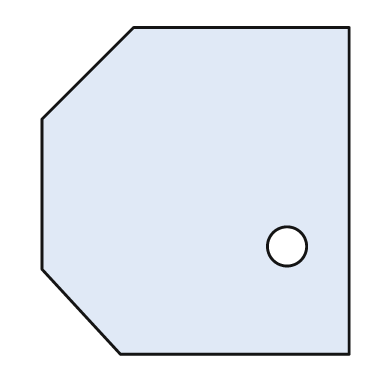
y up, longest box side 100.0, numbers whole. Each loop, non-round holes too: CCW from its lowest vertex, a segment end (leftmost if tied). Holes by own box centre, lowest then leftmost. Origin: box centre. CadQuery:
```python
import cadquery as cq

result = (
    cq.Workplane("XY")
    .moveTo(-23.0, -50.0)
    .lineTo(47.0, -50.0)
    .lineTo(47.0, 50.0)
    .lineTo(-19.0, 50.0)
    .lineTo(-47.0, 22.0)
    .lineTo(-47.0, -24.0)
    .close()
    .moveTo(28.0, -17.0)
    .circle(6.0)
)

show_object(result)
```